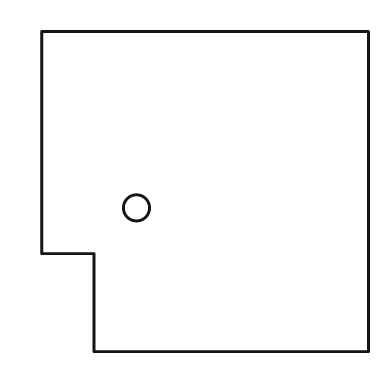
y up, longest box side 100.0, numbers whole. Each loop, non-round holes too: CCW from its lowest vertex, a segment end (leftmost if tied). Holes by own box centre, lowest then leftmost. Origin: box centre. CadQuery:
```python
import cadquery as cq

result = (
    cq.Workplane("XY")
    .moveTo(-34.0, -49.0)
    .lineTo(50.0, -49.0)
    .lineTo(50.0, 49.0)
    .lineTo(-50.0, 49.0)
    .lineTo(-50.0, -19.0)
    .lineTo(-34.0, -19.0)
    .close()
    .moveTo(-21.0, -5.0)
    .circle(4.0)
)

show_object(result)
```